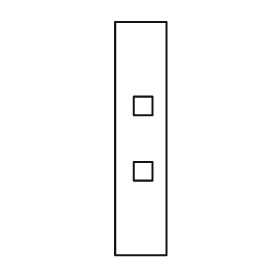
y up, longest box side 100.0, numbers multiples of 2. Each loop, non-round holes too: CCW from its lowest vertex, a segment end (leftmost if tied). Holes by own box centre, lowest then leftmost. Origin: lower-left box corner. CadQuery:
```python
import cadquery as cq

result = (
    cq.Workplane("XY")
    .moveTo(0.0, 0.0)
    .lineTo(22.0, 0.0)
    .lineTo(22.0, 100.0)
    .lineTo(0.0, 100.0)
    .close()
    .moveTo(8.0, 32.0)
    .lineTo(16.0, 32.0)
    .lineTo(16.0, 40.0)
    .lineTo(8.0, 40.0)
    .close()
    .moveTo(8.0, 60.0)
    .lineTo(16.0, 60.0)
    .lineTo(16.0, 68.0)
    .lineTo(8.0, 68.0)
    .close()
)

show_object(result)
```